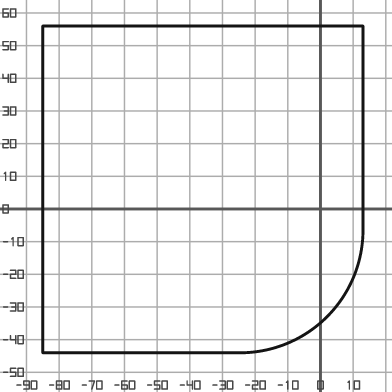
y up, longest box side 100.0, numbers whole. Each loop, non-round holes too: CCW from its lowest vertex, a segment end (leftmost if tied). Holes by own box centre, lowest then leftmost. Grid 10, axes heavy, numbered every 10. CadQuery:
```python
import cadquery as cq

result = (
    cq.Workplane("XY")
    .moveTo(-85.0, -44.0)
    .lineTo(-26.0, -44.0)
    .threePointArc((2.0, -33.0), (13.0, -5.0))
    .lineTo(13.0, 56.0)
    .lineTo(-85.0, 56.0)
    .close()
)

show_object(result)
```